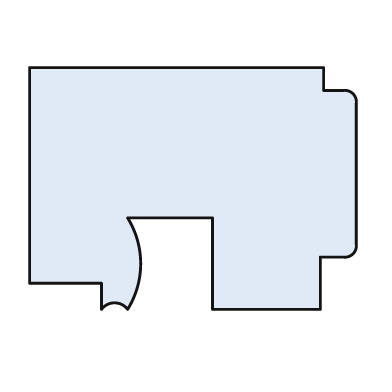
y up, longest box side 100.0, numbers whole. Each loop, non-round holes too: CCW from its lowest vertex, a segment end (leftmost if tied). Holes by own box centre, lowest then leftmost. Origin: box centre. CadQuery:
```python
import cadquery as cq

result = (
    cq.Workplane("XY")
    .moveTo(-28.0, -37.0)
    .threePointArc((-24.0, -35.0), (-20.0, -37.0))
    .threePointArc((-16.0, -23.0), (-20.0, -9.0))
    .lineTo(6.0, -9.0)
    .lineTo(6.0, -37.0)
    .lineTo(39.0, -37.0)
    .lineTo(39.0, -21.0)
    .lineTo(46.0, -21.0)
    .threePointArc((49.0, -20.0), (50.0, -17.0))
    .lineTo(50.0, 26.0)
    .threePointArc((49.0, 29.0), (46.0, 30.0))
    .lineTo(40.0, 30.0)
    .lineTo(40.0, 37.0)
    .lineTo(-50.0, 37.0)
    .lineTo(-50.0, -29.0)
    .lineTo(-28.0, -29.0)
    .close()
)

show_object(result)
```